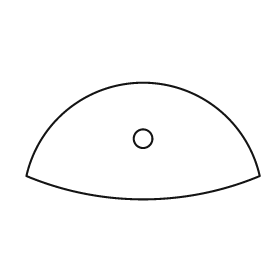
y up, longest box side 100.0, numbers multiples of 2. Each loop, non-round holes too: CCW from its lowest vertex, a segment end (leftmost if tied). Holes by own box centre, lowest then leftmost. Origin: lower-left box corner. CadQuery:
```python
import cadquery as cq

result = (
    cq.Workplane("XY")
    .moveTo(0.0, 10.0)
    .threePointArc((50.0, 0.0), (100.0, 10.0))
    .threePointArc((50.0, 50.0), (0.0, 10.0))
    .close()
    .moveTo(50.0, 26.0)
    .circle(4.0)
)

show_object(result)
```